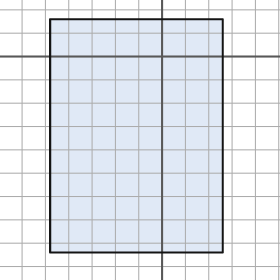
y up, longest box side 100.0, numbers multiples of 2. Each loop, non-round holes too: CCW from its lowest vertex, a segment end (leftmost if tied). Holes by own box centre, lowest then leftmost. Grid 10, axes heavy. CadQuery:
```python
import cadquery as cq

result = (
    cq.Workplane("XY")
    .moveTo(-48.0, -84.0)
    .lineTo(26.0, -84.0)
    .lineTo(26.0, 16.0)
    .lineTo(-48.0, 16.0)
    .close()
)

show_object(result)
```